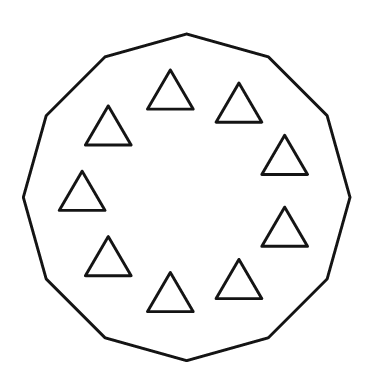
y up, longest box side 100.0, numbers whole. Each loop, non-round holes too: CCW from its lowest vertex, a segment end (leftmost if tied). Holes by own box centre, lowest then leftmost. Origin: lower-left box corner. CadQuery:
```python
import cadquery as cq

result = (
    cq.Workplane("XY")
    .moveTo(50.0, 0.0)
    .lineTo(75.0, 7.0)
    .lineTo(93.0, 25.0)
    .lineTo(100.0, 50.0)
    .lineTo(93.0, 75.0)
    .lineTo(75.0, 93.0)
    .lineTo(50.0, 100.0)
    .lineTo(25.0, 93.0)
    .lineTo(7.0, 75.0)
    .lineTo(0.0, 50.0)
    .lineTo(7.0, 25.0)
    .lineTo(25.0, 7.0)
    .close()
    .moveTo(38.0, 15.0)
    .lineTo(52.0, 15.0)
    .lineTo(45.0, 27.0)
    .close()
    .moveTo(59.0, 19.0)
    .lineTo(73.0, 19.0)
    .lineTo(66.0, 31.0)
    .close()
    .moveTo(19.0, 26.0)
    .lineTo(33.0, 26.0)
    .lineTo(26.0, 38.0)
    .close()
    .moveTo(73.0, 35.0)
    .lineTo(87.0, 35.0)
    .lineTo(80.0, 47.0)
    .close()
    .moveTo(11.0, 46.0)
    .lineTo(25.0, 46.0)
    .lineTo(18.0, 58.0)
    .close()
    .moveTo(73.0, 57.0)
    .lineTo(87.0, 57.0)
    .lineTo(80.0, 69.0)
    .close()
    .moveTo(19.0, 66.0)
    .lineTo(33.0, 66.0)
    .lineTo(26.0, 78.0)
    .close()
    .moveTo(59.0, 73.0)
    .lineTo(73.0, 73.0)
    .lineTo(66.0, 85.0)
    .close()
    .moveTo(38.0, 77.0)
    .lineTo(52.0, 77.0)
    .lineTo(45.0, 89.0)
    .close()
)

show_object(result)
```